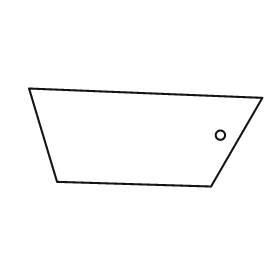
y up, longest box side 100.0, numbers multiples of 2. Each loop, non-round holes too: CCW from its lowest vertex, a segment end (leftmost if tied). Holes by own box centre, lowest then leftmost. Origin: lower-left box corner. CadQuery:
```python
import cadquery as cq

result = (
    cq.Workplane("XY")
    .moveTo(78.0, 0.0)
    .lineTo(100.0, 38.0)
    .lineTo(0.0, 42.0)
    .lineTo(12.0, 2.0)
    .close()
    .moveTo(82.0, 22.0)
    .circle(2.0)
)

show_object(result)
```